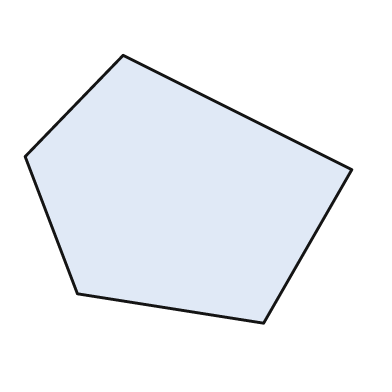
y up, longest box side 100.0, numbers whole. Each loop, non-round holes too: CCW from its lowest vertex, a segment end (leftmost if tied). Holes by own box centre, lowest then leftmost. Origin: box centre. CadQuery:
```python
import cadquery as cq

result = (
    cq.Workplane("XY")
    .moveTo(23.0, -41.0)
    .lineTo(50.0, 6.0)
    .lineTo(-20.0, 41.0)
    .lineTo(-50.0, 10.0)
    .lineTo(-34.0, -32.0)
    .close()
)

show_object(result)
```